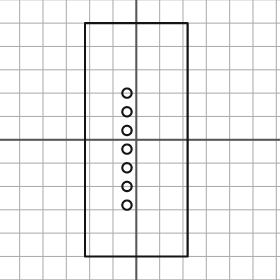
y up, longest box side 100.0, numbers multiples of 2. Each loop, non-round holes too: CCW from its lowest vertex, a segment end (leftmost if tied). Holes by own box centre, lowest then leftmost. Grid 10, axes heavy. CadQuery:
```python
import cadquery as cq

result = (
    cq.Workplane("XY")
    .moveTo(-22.0, -50.0)
    .lineTo(22.0, -50.0)
    .lineTo(22.0, 50.0)
    .lineTo(-22.0, 50.0)
    .close()
    .moveTo(-4.0, -28.0)
    .circle(2.0)
    .moveTo(-4.0, -20.0)
    .circle(2.0)
    .moveTo(-4.0, -12.0)
    .circle(2.0)
    .moveTo(-4.0, -4.0)
    .circle(2.0)
    .moveTo(-4.0, 4.0)
    .circle(2.0)
    .moveTo(-4.0, 12.0)
    .circle(2.0)
    .moveTo(-4.0, 20.0)
    .circle(2.0)
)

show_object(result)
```